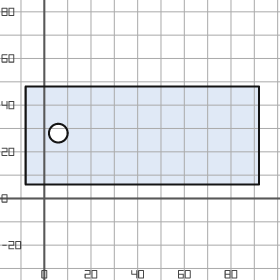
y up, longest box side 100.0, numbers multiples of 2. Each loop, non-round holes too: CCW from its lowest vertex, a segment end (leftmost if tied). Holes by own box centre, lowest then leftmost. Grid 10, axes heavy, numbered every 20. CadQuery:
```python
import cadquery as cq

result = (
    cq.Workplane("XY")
    .moveTo(-8.0, 6.0)
    .lineTo(92.0, 6.0)
    .lineTo(92.0, 48.0)
    .lineTo(-8.0, 48.0)
    .close()
    .moveTo(6.0, 28.0)
    .circle(4.0)
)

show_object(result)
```